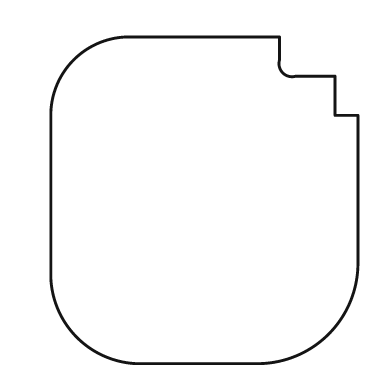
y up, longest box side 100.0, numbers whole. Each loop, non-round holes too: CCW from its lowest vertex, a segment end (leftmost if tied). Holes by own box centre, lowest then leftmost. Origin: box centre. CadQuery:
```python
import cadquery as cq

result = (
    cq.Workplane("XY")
    .moveTo(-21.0, -50.0)
    .lineTo(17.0, -50.0)
    .threePointArc((38.0, -41.0), (47.0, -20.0))
    .lineTo(47.0, 26.0)
    .lineTo(40.0, 26.0)
    .lineTo(40.0, 38.0)
    .lineTo(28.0, 38.0)
    .threePointArc((24.0, 39.0), (23.0, 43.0))
    .lineTo(23.0, 50.0)
    .lineTo(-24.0, 50.0)
    .threePointArc((-40.0, 43.0), (-47.0, 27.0))
    .lineTo(-47.0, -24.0)
    .threePointArc((-39.0, -42.0), (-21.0, -50.0))
    .close()
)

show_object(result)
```